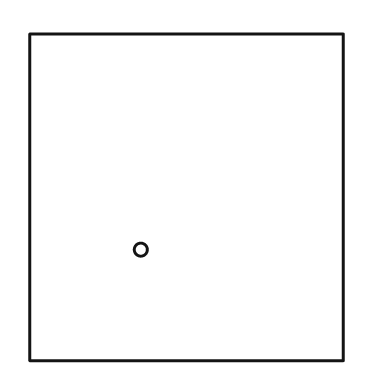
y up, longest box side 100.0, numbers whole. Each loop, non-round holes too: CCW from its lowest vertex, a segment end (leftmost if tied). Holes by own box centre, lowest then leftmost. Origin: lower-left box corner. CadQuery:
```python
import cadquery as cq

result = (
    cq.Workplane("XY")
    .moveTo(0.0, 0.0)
    .lineTo(96.0, 0.0)
    .lineTo(96.0, 100.0)
    .lineTo(0.0, 100.0)
    .close()
    .moveTo(34.0, 34.0)
    .circle(2.0)
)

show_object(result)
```